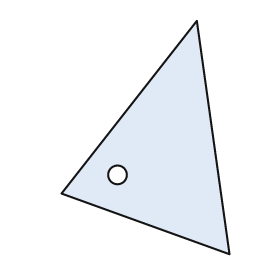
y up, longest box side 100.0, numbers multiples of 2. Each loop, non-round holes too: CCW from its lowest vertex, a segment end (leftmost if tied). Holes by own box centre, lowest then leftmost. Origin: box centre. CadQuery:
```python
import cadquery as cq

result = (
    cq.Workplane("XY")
    .moveTo(36.0, -50.0)
    .lineTo(22.0, 50.0)
    .lineTo(-36.0, -24.0)
    .close()
    .moveTo(-12.0, -16.0)
    .circle(4.0)
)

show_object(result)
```